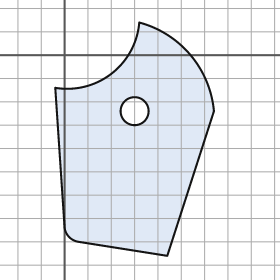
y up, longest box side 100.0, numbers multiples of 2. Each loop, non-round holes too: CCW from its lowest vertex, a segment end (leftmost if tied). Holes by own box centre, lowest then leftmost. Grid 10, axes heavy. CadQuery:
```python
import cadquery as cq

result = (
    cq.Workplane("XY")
    .moveTo(44.0, -86.0)
    .lineTo(64.0, -24.0)
    .threePointArc((54.0, 0.0), (32.0, 14.0))
    .threePointArc((20.0, -8.0), (-4.0, -14.0))
    .lineTo(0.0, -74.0)
    .threePointArc((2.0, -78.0), (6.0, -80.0))
    .close()
    .moveTo(30.0, -24.0)
    .circle(6.0)
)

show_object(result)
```